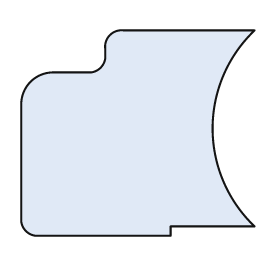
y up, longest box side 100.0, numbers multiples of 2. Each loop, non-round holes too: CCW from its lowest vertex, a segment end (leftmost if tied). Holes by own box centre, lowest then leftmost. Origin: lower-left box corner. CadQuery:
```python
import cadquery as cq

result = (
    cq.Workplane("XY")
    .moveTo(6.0, 0.0)
    .lineTo(64.0, 0.0)
    .lineTo(64.0, 4.0)
    .lineTo(100.0, 4.0)
    .threePointArc((82.0, 46.0), (100.0, 88.0))
    .lineTo(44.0, 88.0)
    .threePointArc((38.0, 86.0), (36.0, 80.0))
    .lineTo(36.0, 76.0)
    .threePointArc((34.0, 72.0), (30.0, 70.0))
    .lineTo(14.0, 70.0)
    .threePointArc((4.0, 66.0), (0.0, 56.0))
    .lineTo(0.0, 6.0)
    .threePointArc((2.0, 2.0), (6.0, 0.0))
    .close()
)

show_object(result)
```